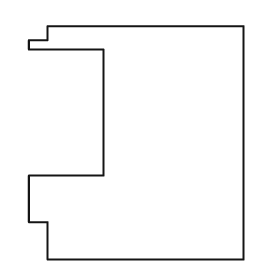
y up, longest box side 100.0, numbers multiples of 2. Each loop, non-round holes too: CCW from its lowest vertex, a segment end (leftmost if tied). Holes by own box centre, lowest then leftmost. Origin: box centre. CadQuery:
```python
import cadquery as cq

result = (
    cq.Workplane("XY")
    .moveTo(-38.0, -50.0)
    .lineTo(46.0, -50.0)
    .lineTo(46.0, 50.0)
    .lineTo(-38.0, 50.0)
    .lineTo(-38.0, 44.0)
    .lineTo(-46.0, 44.0)
    .lineTo(-46.0, 40.0)
    .lineTo(-14.0, 40.0)
    .lineTo(-14.0, -14.0)
    .lineTo(-46.0, -14.0)
    .lineTo(-46.0, -34.0)
    .lineTo(-38.0, -34.0)
    .close()
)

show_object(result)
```